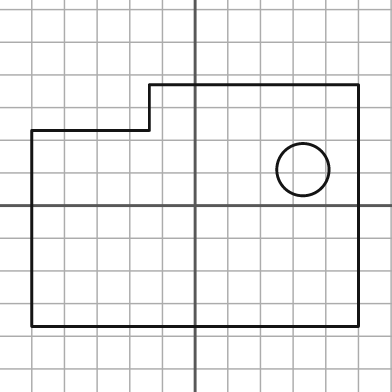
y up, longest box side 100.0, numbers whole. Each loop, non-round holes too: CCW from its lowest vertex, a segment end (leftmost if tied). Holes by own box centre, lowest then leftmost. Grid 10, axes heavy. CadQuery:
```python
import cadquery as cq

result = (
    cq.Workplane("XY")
    .moveTo(-50.0, -37.0)
    .lineTo(50.0, -37.0)
    .lineTo(50.0, 37.0)
    .lineTo(-14.0, 37.0)
    .lineTo(-14.0, 23.0)
    .lineTo(-50.0, 23.0)
    .close()
    .moveTo(33.0, 11.0)
    .circle(8.0)
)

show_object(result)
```